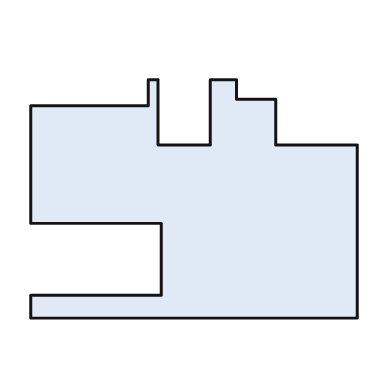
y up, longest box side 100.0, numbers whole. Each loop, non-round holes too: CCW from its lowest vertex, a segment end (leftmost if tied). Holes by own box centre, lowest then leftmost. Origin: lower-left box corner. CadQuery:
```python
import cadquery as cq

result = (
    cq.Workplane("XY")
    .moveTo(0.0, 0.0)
    .lineTo(100.0, 0.0)
    .lineTo(100.0, 53.0)
    .lineTo(75.0, 53.0)
    .lineTo(75.0, 67.0)
    .lineTo(63.0, 67.0)
    .lineTo(63.0, 73.0)
    .lineTo(55.0, 73.0)
    .lineTo(55.0, 53.0)
    .lineTo(39.0, 53.0)
    .lineTo(39.0, 73.0)
    .lineTo(36.0, 73.0)
    .lineTo(36.0, 65.0)
    .lineTo(0.0, 65.0)
    .lineTo(0.0, 29.0)
    .lineTo(40.0, 29.0)
    .lineTo(40.0, 7.0)
    .lineTo(0.0, 7.0)
    .close()
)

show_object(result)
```